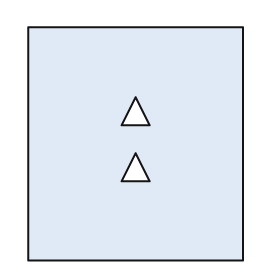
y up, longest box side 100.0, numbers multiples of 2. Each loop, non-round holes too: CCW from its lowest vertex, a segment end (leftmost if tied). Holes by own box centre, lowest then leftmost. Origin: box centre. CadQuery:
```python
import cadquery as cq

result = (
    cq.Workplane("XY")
    .moveTo(-46.0, -50.0)
    .lineTo(46.0, -50.0)
    .lineTo(46.0, 50.0)
    .lineTo(-46.0, 50.0)
    .close()
    .moveTo(-6.0, -16.0)
    .lineTo(6.0, -16.0)
    .lineTo(0.0, -4.0)
    .close()
    .moveTo(-6.0, 8.0)
    .lineTo(6.0, 8.0)
    .lineTo(0.0, 20.0)
    .close()
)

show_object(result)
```